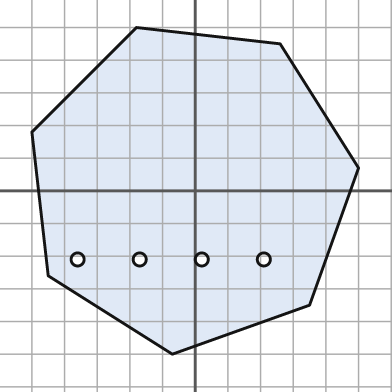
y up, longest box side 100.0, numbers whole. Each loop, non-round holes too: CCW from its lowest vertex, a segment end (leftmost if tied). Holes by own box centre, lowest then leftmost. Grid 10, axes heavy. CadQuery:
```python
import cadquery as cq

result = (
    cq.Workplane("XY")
    .moveTo(-7.0, -50.0)
    .lineTo(35.0, -35.0)
    .lineTo(50.0, 7.0)
    .lineTo(26.0, 45.0)
    .lineTo(-18.0, 50.0)
    .lineTo(-50.0, 18.0)
    .lineTo(-45.0, -26.0)
    .close()
    .moveTo(-36.0, -21.0)
    .circle(2.0)
    .moveTo(-17.0, -21.0)
    .circle(2.0)
    .moveTo(2.0, -21.0)
    .circle(2.0)
    .moveTo(21.0, -21.0)
    .circle(2.0)
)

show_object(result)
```